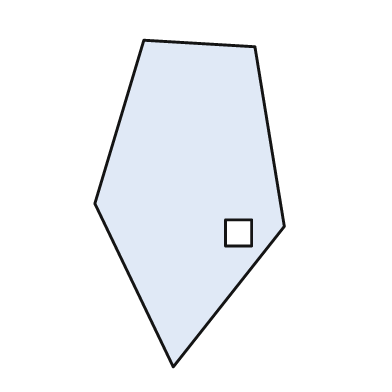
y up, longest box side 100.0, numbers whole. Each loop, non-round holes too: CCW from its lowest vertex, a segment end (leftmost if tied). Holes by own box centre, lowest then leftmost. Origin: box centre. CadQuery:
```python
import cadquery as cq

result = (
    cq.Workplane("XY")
    .moveTo(-5.0, -50.0)
    .lineTo(29.0, -7.0)
    .lineTo(20.0, 48.0)
    .lineTo(-14.0, 50.0)
    .lineTo(-29.0, 0.0)
    .close()
    .moveTo(11.0, -13.0)
    .lineTo(19.0, -13.0)
    .lineTo(19.0, -5.0)
    .lineTo(11.0, -5.0)
    .close()
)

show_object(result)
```